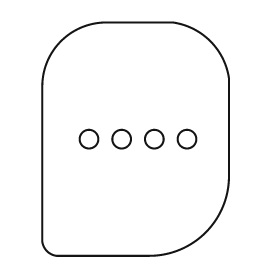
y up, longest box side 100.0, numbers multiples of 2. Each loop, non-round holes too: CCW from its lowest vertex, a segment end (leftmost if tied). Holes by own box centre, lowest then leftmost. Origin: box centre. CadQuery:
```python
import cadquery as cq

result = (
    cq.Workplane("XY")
    .moveTo(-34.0, -50.0)
    .lineTo(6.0, -50.0)
    .threePointArc((30.0, -40.0), (40.0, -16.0))
    .lineTo(40.0, 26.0)
    .threePointArc((32.0, 42.0), (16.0, 50.0))
    .lineTo(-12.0, 50.0)
    .threePointArc((-32.0, 42.0), (-40.0, 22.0))
    .lineTo(-40.0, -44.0)
    .threePointArc((-38.0, -48.0), (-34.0, -50.0))
    .close()
    .moveTo(-20.0, 0.0)
    .circle(4.0)
    .moveTo(-6.0, 0.0)
    .circle(4.0)
    .moveTo(8.0, 0.0)
    .circle(4.0)
    .moveTo(22.0, 0.0)
    .circle(4.0)
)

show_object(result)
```